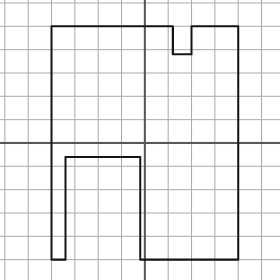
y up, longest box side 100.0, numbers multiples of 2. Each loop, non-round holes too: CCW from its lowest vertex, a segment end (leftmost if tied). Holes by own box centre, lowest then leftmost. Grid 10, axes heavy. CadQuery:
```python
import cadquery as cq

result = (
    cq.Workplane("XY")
    .moveTo(-40.0, -50.0)
    .lineTo(-34.0, -50.0)
    .lineTo(-34.0, -6.0)
    .lineTo(-2.0, -6.0)
    .lineTo(-2.0, -50.0)
    .lineTo(40.0, -50.0)
    .lineTo(40.0, 50.0)
    .lineTo(20.0, 50.0)
    .lineTo(20.0, 38.0)
    .lineTo(12.0, 38.0)
    .lineTo(12.0, 50.0)
    .lineTo(-40.0, 50.0)
    .close()
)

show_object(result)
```